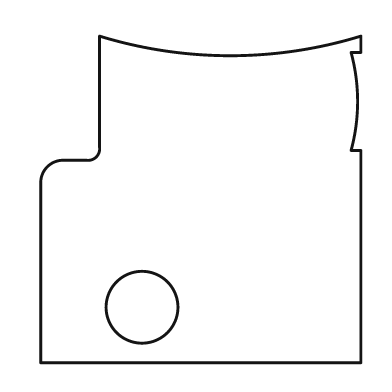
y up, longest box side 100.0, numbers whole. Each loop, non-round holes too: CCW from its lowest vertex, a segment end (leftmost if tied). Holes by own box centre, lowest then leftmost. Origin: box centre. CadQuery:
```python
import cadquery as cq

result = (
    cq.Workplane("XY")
    .moveTo(-49.0, -50.0)
    .lineTo(49.0, -50.0)
    .lineTo(49.0, 15.0)
    .lineTo(46.0, 15.0)
    .threePointArc((48.0, 30.0), (46.0, 45.0))
    .lineTo(49.0, 45.0)
    .lineTo(49.0, 50.0)
    .threePointArc((9.0, 44.0), (-31.0, 50.0))
    .lineTo(-31.0, 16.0)
    .threePointArc((-32.0, 13.0), (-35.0, 12.0))
    .lineTo(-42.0, 12.0)
    .threePointArc((-47.0, 10.0), (-49.0, 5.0))
    .close()
    .moveTo(-18.0, -33.0)
    .circle(11.0)
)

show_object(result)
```